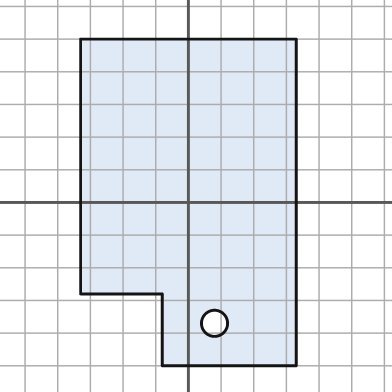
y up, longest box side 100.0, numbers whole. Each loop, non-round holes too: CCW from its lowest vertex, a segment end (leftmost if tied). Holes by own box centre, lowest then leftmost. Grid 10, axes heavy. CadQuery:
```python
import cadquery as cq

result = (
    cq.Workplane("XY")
    .moveTo(-8.0, -50.0)
    .lineTo(33.0, -50.0)
    .lineTo(33.0, 50.0)
    .lineTo(-33.0, 50.0)
    .lineTo(-33.0, -28.0)
    .lineTo(-8.0, -28.0)
    .close()
    .moveTo(8.0, -37.0)
    .circle(4.0)
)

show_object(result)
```